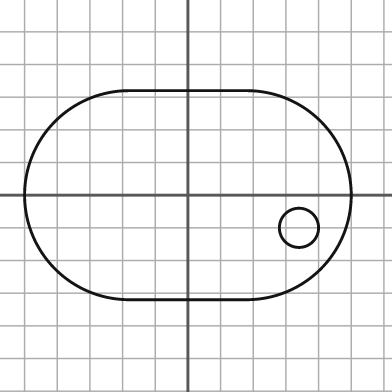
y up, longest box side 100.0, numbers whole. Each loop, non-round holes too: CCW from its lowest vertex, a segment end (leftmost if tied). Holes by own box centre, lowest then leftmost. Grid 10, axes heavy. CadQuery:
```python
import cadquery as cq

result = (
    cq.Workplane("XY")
    .moveTo(-18.0, -32.0)
    .lineTo(18.0, -32.0)
    .threePointArc((50.0, 0.0), (18.0, 32.0))
    .lineTo(-18.0, 32.0)
    .threePointArc((-50.0, 0.0), (-18.0, -32.0))
    .close()
    .moveTo(34.0, -10.0)
    .circle(6.0)
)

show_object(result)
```